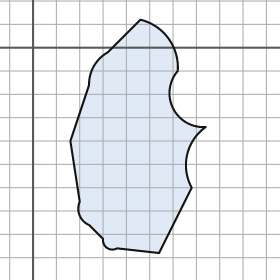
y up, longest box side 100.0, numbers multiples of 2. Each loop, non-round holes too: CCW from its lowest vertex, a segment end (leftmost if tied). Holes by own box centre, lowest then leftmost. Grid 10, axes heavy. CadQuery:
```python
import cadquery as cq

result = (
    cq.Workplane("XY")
    .moveTo(54.0, -88.0)
    .lineTo(68.0, -60.0)
    .threePointArc((66.0, -46.0), (74.0, -34.0))
    .threePointArc((60.0, -26.0), (62.0, -10.0))
    .threePointArc((58.0, 4.0), (46.0, 12.0))
    .lineTo(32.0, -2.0)
    .threePointArc((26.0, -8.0), (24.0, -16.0))
    .lineTo(16.0, -40.0)
    .lineTo(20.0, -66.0)
    .threePointArc((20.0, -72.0), (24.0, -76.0))
    .lineTo(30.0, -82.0)
    .threePointArc((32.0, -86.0), (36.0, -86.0))
    .close()
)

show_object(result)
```